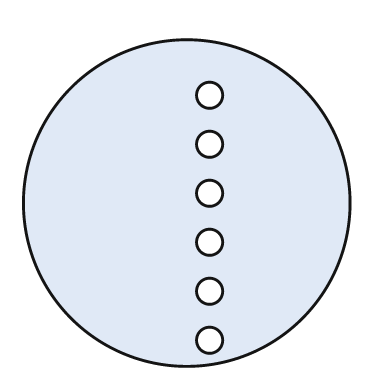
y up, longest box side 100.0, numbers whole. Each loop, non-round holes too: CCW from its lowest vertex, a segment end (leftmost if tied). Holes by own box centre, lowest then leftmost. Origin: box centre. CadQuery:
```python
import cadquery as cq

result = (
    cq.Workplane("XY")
    .moveTo(0.0, 0.0)
    .circle(50.0)
    .moveTo(7.0, -42.0)
    .circle(4.0)
    .moveTo(7.0, -27.0)
    .circle(4.0)
    .moveTo(7.0, -12.0)
    .circle(4.0)
    .moveTo(7.0, 3.0)
    .circle(4.0)
    .moveTo(7.0, 18.0)
    .circle(4.0)
    .moveTo(7.0, 33.0)
    .circle(4.0)
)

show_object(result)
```